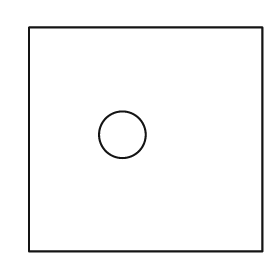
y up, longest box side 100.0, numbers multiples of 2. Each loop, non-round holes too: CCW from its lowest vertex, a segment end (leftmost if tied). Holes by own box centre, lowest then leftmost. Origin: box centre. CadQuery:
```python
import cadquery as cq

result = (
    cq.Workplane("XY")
    .moveTo(-50.0, -48.0)
    .lineTo(50.0, -48.0)
    .lineTo(50.0, 48.0)
    .lineTo(-50.0, 48.0)
    .close()
    .moveTo(-10.0, 2.0)
    .circle(10.0)
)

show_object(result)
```